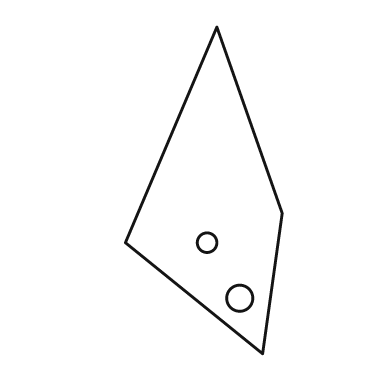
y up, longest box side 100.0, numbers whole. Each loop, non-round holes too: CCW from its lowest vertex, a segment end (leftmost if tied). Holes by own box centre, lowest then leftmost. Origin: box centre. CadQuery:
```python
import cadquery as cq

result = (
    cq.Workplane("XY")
    .moveTo(18.0, -50.0)
    .lineTo(24.0, -7.0)
    .lineTo(4.0, 50.0)
    .lineTo(-24.0, -16.0)
    .close()
    .moveTo(11.0, -33.0)
    .circle(4.0)
    .moveTo(1.0, -16.0)
    .circle(3.0)
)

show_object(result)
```